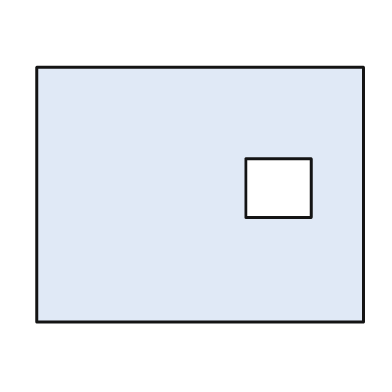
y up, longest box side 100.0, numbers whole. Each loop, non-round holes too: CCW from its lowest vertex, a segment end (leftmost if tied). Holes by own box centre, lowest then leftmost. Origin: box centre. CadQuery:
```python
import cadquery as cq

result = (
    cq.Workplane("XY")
    .moveTo(-50.0, -39.0)
    .lineTo(50.0, -39.0)
    .lineTo(50.0, 39.0)
    .lineTo(-50.0, 39.0)
    .close()
    .moveTo(14.0, -7.0)
    .lineTo(34.0, -7.0)
    .lineTo(34.0, 11.0)
    .lineTo(14.0, 11.0)
    .close()
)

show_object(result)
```